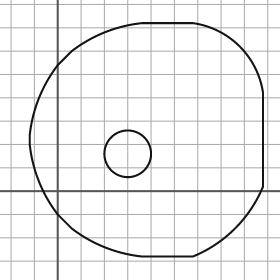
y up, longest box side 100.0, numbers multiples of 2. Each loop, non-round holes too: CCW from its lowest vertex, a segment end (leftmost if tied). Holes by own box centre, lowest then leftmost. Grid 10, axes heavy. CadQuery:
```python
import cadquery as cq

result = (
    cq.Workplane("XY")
    .moveTo(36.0, -28.0)
    .lineTo(58.0, -28.0)
    .threePointArc((76.0, -16.0), (88.0, 2.0))
    .lineTo(88.0, 42.0)
    .threePointArc((78.0, 62.0), (58.0, 72.0))
    .lineTo(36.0, 72.0)
    .threePointArc((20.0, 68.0), (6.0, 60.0))
    .lineTo(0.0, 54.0)
    .threePointArc((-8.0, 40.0), (-12.0, 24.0))
    .lineTo(-12.0, 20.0)
    .threePointArc((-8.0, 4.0), (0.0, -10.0))
    .lineTo(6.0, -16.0)
    .threePointArc((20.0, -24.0), (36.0, -28.0))
    .close()
    .moveTo(30.0, 16.0)
    .circle(10.0)
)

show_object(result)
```